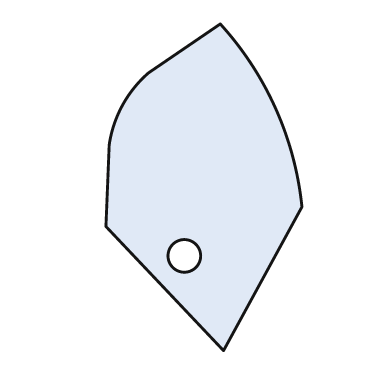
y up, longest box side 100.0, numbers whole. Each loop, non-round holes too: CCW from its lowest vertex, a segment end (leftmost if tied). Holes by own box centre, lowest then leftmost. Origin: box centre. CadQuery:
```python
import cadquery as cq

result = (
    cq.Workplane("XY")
    .moveTo(6.0, -50.0)
    .lineTo(30.0, -6.0)
    .threePointArc((22.0, 24.0), (5.0, 50.0))
    .lineTo(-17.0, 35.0)
    .threePointArc((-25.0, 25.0), (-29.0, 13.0))
    .lineTo(-30.0, -12.0)
    .close()
    .moveTo(-6.0, -21.0)
    .circle(5.0)
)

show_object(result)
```